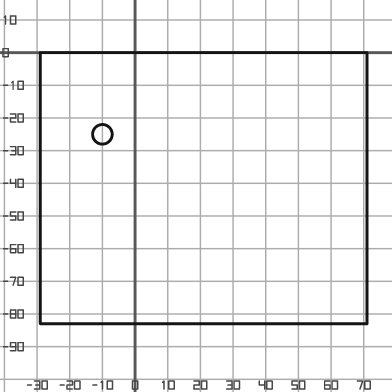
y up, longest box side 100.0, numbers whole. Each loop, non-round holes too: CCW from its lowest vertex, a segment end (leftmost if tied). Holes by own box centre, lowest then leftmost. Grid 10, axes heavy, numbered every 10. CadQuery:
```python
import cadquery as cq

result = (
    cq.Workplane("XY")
    .moveTo(-29.0, -83.0)
    .lineTo(71.0, -83.0)
    .lineTo(71.0, 0.0)
    .lineTo(-29.0, 0.0)
    .close()
    .moveTo(-10.0, -25.0)
    .circle(3.0)
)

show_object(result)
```